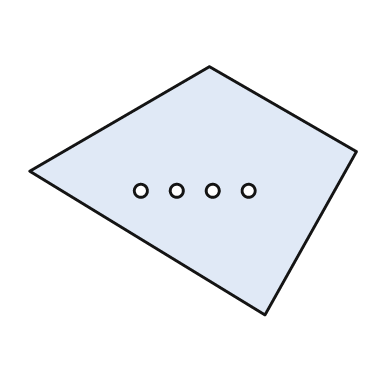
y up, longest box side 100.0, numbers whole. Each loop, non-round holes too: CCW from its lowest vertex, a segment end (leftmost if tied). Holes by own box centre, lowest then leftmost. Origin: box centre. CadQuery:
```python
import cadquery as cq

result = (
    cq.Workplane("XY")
    .moveTo(22.0, -38.0)
    .lineTo(50.0, 12.0)
    .lineTo(5.0, 38.0)
    .lineTo(-50.0, 6.0)
    .close()
    .moveTo(-16.0, 0.0)
    .circle(2.0)
    .moveTo(-5.0, 0.0)
    .circle(2.0)
    .moveTo(6.0, 0.0)
    .circle(2.0)
    .moveTo(17.0, 0.0)
    .circle(2.0)
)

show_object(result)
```